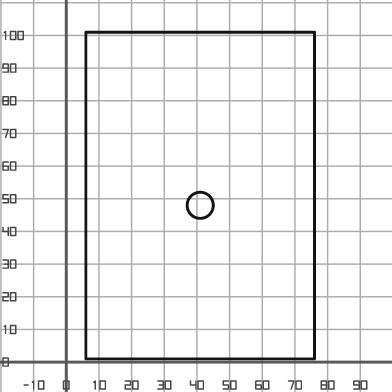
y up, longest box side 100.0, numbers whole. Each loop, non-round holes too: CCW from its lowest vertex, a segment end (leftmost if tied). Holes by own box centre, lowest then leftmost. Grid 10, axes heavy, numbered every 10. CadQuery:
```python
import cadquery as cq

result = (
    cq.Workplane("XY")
    .moveTo(6.0, 1.0)
    .lineTo(76.0, 1.0)
    .lineTo(76.0, 101.0)
    .lineTo(6.0, 101.0)
    .close()
    .moveTo(41.0, 48.0)
    .circle(4.0)
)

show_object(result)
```